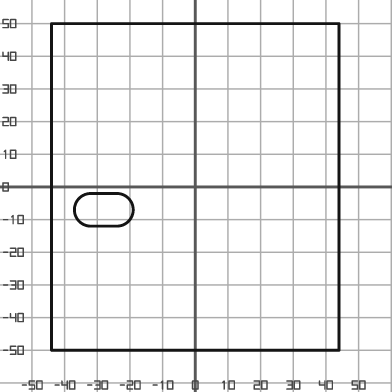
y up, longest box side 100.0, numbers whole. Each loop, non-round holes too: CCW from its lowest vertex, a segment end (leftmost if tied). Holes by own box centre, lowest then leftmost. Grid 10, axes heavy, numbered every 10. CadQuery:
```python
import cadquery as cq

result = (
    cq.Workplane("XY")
    .moveTo(-44.0, -50.0)
    .lineTo(44.0, -50.0)
    .lineTo(44.0, 50.0)
    .lineTo(-44.0, 50.0)
    .close()
    .moveTo(-32.0, -12.0)
    .lineTo(-24.0, -12.0)
    .threePointArc((-19.0, -7.0), (-24.0, -2.0))
    .lineTo(-32.0, -2.0)
    .threePointArc((-37.0, -7.0), (-32.0, -12.0))
    .close()
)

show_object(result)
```